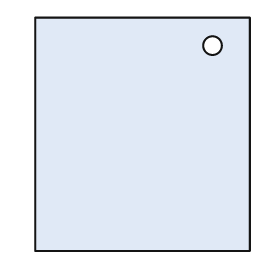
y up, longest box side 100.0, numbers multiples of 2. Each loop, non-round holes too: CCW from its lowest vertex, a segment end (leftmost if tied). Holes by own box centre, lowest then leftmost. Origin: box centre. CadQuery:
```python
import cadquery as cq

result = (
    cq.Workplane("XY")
    .moveTo(-46.0, -50.0)
    .lineTo(46.0, -50.0)
    .lineTo(46.0, 50.0)
    .lineTo(-46.0, 50.0)
    .close()
    .moveTo(30.0, 38.0)
    .circle(4.0)
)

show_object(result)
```